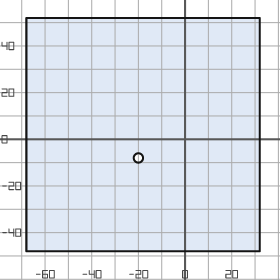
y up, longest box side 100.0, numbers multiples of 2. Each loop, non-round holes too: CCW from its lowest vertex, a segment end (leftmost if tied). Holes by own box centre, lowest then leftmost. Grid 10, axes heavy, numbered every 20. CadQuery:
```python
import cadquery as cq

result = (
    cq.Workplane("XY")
    .moveTo(-68.0, -48.0)
    .lineTo(32.0, -48.0)
    .lineTo(32.0, 52.0)
    .lineTo(-68.0, 52.0)
    .close()
    .moveTo(-20.0, -8.0)
    .circle(2.0)
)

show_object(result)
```